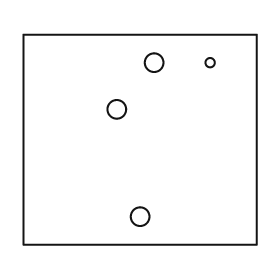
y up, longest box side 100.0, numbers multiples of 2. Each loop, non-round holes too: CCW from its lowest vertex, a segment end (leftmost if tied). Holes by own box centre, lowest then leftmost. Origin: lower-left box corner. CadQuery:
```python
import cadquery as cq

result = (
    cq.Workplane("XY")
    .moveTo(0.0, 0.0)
    .lineTo(100.0, 0.0)
    .lineTo(100.0, 90.0)
    .lineTo(0.0, 90.0)
    .close()
    .moveTo(50.0, 12.0)
    .circle(4.0)
    .moveTo(40.0, 58.0)
    .circle(4.0)
    .moveTo(56.0, 78.0)
    .circle(4.0)
    .moveTo(80.0, 78.0)
    .circle(2.0)
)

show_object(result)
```